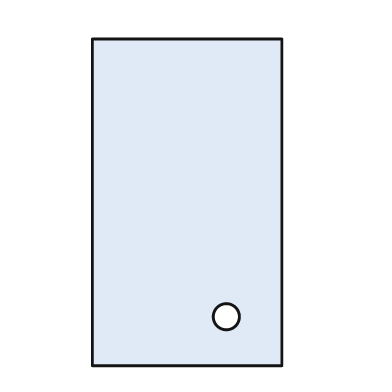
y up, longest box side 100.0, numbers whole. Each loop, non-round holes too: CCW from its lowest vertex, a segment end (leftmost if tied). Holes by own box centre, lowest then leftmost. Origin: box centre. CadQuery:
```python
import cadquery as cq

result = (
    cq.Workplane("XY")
    .moveTo(-29.0, -50.0)
    .lineTo(29.0, -50.0)
    .lineTo(29.0, 50.0)
    .lineTo(-29.0, 50.0)
    .close()
    .moveTo(12.0, -35.0)
    .circle(4.0)
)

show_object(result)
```